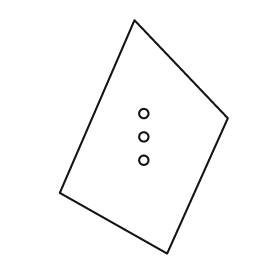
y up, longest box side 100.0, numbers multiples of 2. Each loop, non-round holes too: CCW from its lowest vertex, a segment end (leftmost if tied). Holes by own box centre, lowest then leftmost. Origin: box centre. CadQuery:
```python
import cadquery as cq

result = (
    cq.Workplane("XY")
    .moveTo(10.0, -50.0)
    .lineTo(36.0, 8.0)
    .lineTo(-4.0, 50.0)
    .lineTo(-36.0, -24.0)
    .close()
    .moveTo(0.0, -10.0)
    .circle(2.0)
    .moveTo(0.0, 0.0)
    .circle(2.0)
    .moveTo(0.0, 10.0)
    .circle(2.0)
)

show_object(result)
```